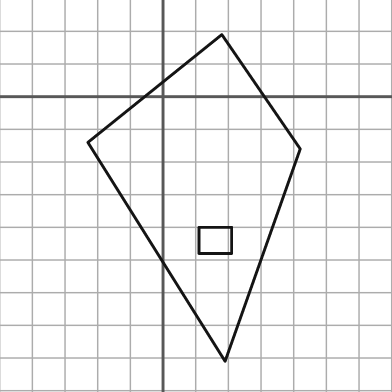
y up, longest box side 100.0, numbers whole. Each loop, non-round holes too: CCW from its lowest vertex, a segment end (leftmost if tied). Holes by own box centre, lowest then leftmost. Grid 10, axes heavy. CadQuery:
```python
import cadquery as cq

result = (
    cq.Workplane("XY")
    .moveTo(19.0, -81.0)
    .lineTo(42.0, -16.0)
    .lineTo(18.0, 19.0)
    .lineTo(-23.0, -14.0)
    .close()
    .moveTo(11.0, -48.0)
    .lineTo(21.0, -48.0)
    .lineTo(21.0, -40.0)
    .lineTo(11.0, -40.0)
    .close()
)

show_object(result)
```